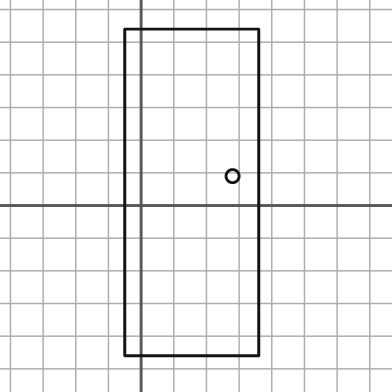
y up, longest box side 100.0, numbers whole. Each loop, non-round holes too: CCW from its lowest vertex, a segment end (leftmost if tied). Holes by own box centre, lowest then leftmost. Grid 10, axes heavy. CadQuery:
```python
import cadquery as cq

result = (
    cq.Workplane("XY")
    .moveTo(-5.0, -46.0)
    .lineTo(36.0, -46.0)
    .lineTo(36.0, 54.0)
    .lineTo(-5.0, 54.0)
    .close()
    .moveTo(28.0, 9.0)
    .circle(2.0)
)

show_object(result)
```